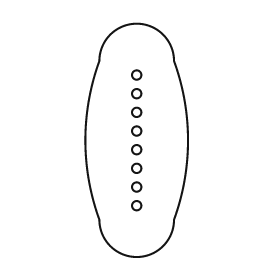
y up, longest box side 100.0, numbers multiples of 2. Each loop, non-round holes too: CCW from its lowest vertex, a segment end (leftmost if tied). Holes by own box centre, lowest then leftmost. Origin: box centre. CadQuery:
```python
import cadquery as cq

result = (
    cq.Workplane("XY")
    .moveTo(-16.0, -34.0)
    .threePointArc((0.0, -50.0), (16.0, -34.0))
    .threePointArc((22.0, 0.0), (16.0, 34.0))
    .threePointArc((0.0, 50.0), (-16.0, 34.0))
    .threePointArc((-22.0, 0.0), (-16.0, -34.0))
    .close()
    .moveTo(0.0, -28.0)
    .circle(2.0)
    .moveTo(0.0, -20.0)
    .circle(2.0)
    .moveTo(0.0, -12.0)
    .circle(2.0)
    .moveTo(0.0, -4.0)
    .circle(2.0)
    .moveTo(0.0, 4.0)
    .circle(2.0)
    .moveTo(0.0, 12.0)
    .circle(2.0)
    .moveTo(0.0, 20.0)
    .circle(2.0)
    .moveTo(0.0, 28.0)
    .circle(2.0)
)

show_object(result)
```